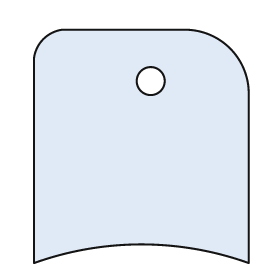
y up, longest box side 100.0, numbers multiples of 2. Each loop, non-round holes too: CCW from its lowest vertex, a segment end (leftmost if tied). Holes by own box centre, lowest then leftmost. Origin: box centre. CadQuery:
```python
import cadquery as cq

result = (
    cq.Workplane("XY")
    .moveTo(-46.0, -50.0)
    .threePointArc((0.0, -42.0), (46.0, -50.0))
    .lineTo(46.0, 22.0)
    .threePointArc((38.0, 42.0), (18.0, 50.0))
    .lineTo(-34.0, 50.0)
    .threePointArc((-42.0, 46.0), (-46.0, 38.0))
    .close()
    .moveTo(4.0, 28.0)
    .circle(6.0)
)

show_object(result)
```